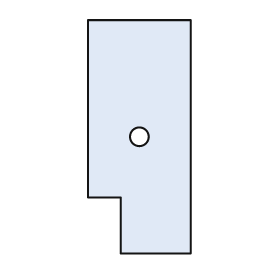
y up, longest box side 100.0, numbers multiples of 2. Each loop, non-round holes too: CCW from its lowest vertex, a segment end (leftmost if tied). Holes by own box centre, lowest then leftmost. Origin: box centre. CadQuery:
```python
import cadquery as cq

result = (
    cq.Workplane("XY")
    .moveTo(-8.0, -50.0)
    .lineTo(22.0, -50.0)
    .lineTo(22.0, 50.0)
    .lineTo(-22.0, 50.0)
    .lineTo(-22.0, -26.0)
    .lineTo(-8.0, -26.0)
    .close()
    .moveTo(0.0, 0.0)
    .circle(4.0)
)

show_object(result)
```